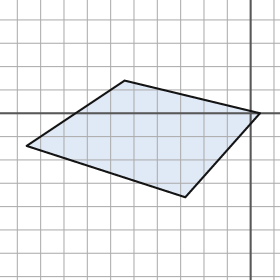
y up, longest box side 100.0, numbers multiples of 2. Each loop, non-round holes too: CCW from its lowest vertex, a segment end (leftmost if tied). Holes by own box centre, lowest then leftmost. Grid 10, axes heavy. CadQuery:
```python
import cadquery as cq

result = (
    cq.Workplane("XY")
    .moveTo(-28.0, -36.0)
    .lineTo(4.0, 0.0)
    .lineTo(-54.0, 14.0)
    .lineTo(-96.0, -14.0)
    .close()
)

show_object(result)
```